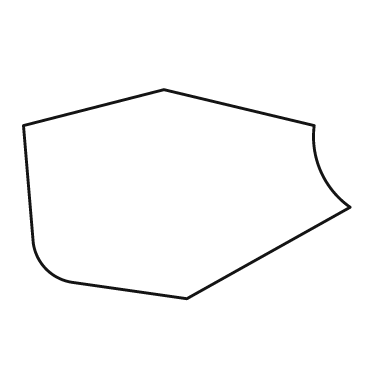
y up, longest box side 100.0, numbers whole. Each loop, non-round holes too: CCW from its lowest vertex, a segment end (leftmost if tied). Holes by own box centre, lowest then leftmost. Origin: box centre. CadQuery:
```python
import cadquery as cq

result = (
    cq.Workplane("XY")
    .moveTo(0.0, -32.0)
    .lineTo(50.0, -4.0)
    .threePointArc((41.0, 7.0), (39.0, 21.0))
    .lineTo(-7.0, 32.0)
    .lineTo(-50.0, 21.0)
    .lineTo(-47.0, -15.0)
    .threePointArc((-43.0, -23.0), (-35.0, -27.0))
    .close()
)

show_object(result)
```